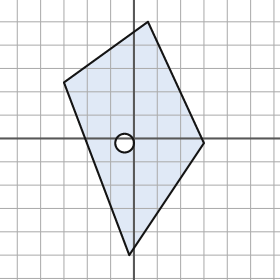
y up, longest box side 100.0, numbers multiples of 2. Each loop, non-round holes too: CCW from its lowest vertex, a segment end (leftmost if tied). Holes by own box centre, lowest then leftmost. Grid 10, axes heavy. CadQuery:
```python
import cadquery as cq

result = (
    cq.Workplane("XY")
    .moveTo(-2.0, -50.0)
    .lineTo(30.0, -2.0)
    .lineTo(6.0, 50.0)
    .lineTo(-30.0, 24.0)
    .close()
    .moveTo(-4.0, -2.0)
    .circle(4.0)
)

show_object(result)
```